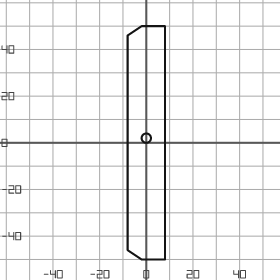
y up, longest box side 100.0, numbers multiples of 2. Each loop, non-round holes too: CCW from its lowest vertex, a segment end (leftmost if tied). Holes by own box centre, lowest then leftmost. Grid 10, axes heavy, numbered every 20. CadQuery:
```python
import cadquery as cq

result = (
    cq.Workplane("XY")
    .moveTo(-2.0, -50.0)
    .lineTo(8.0, -50.0)
    .lineTo(8.0, 50.0)
    .lineTo(-2.0, 50.0)
    .lineTo(-8.0, 46.0)
    .lineTo(-8.0, -46.0)
    .close()
    .moveTo(0.0, 2.0)
    .circle(2.0)
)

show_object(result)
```